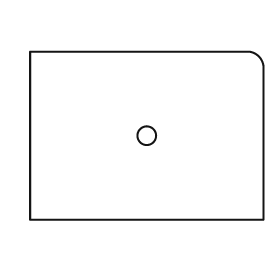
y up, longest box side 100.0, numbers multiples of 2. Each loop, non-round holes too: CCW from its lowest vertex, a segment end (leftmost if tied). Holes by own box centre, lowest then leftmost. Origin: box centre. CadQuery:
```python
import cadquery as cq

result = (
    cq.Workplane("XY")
    .moveTo(-50.0, -36.0)
    .lineTo(50.0, -36.0)
    .lineTo(50.0, 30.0)
    .threePointArc((48.0, 34.0), (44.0, 36.0))
    .lineTo(-50.0, 36.0)
    .close()
    .moveTo(0.0, 0.0)
    .circle(4.0)
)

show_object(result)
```